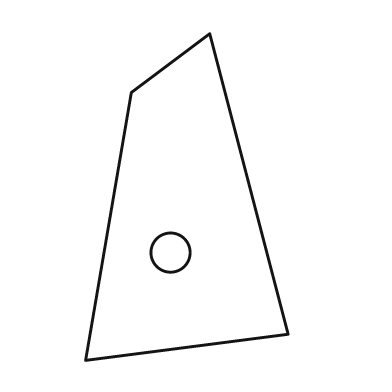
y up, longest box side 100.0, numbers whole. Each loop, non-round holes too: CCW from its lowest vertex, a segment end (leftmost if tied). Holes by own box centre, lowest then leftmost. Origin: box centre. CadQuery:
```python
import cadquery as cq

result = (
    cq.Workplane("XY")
    .moveTo(-31.0, -50.0)
    .lineTo(31.0, -42.0)
    .lineTo(7.0, 50.0)
    .lineTo(-17.0, 32.0)
    .close()
    .moveTo(-5.0, -17.0)
    .circle(6.0)
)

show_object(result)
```